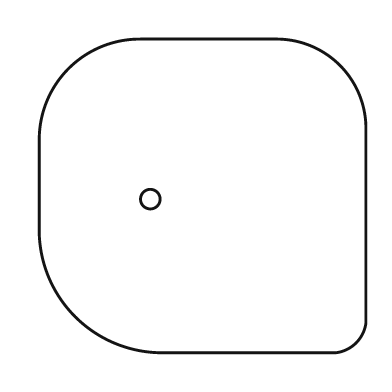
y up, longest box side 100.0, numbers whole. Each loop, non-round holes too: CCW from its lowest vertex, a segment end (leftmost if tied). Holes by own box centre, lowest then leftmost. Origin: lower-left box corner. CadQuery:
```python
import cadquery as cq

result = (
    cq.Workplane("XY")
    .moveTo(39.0, 0.0)
    .lineTo(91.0, 0.0)
    .threePointArc((97.0, 3.0), (100.0, 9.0))
    .lineTo(100.0, 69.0)
    .threePointArc((92.0, 88.0), (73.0, 96.0))
    .lineTo(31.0, 96.0)
    .threePointArc((9.0, 87.0), (0.0, 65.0))
    .lineTo(0.0, 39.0)
    .threePointArc((11.0, 11.0), (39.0, 0.0))
    .close()
    .moveTo(34.0, 47.0)
    .circle(3.0)
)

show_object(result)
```